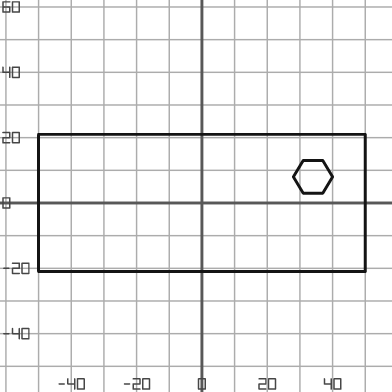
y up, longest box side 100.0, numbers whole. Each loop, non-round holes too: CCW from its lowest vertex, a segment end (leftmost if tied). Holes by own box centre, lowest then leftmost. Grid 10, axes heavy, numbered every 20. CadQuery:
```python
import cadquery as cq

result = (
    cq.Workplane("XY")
    .moveTo(-50.0, -21.0)
    .lineTo(50.0, -21.0)
    .lineTo(50.0, 21.0)
    .lineTo(-50.0, 21.0)
    .close()
    .moveTo(31.0, 3.0)
    .lineTo(37.0, 3.0)
    .lineTo(40.0, 8.0)
    .lineTo(37.0, 13.0)
    .lineTo(31.0, 13.0)
    .lineTo(28.0, 8.0)
    .close()
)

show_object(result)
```